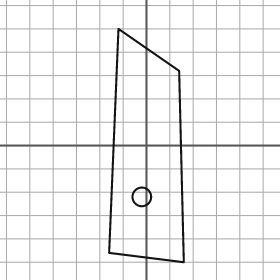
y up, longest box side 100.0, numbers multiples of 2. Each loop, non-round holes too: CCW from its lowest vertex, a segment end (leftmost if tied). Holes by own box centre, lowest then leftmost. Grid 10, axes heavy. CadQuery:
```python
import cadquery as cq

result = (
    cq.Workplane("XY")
    .moveTo(16.0, -50.0)
    .lineTo(14.0, 32.0)
    .lineTo(-12.0, 50.0)
    .lineTo(-16.0, -46.0)
    .close()
    .moveTo(-2.0, -22.0)
    .circle(4.0)
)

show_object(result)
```